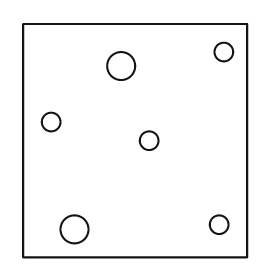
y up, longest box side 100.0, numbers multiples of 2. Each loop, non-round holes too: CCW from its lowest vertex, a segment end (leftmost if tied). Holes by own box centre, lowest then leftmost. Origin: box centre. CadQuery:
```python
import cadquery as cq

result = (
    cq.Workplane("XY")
    .moveTo(-48.0, -50.0)
    .lineTo(48.0, -50.0)
    .lineTo(48.0, 50.0)
    .lineTo(-48.0, 50.0)
    .close()
    .moveTo(-26.0, -38.0)
    .circle(6.0)
    .moveTo(36.0, -36.0)
    .circle(4.0)
    .moveTo(6.0, 0.0)
    .circle(4.0)
    .moveTo(-36.0, 8.0)
    .circle(4.0)
    .moveTo(-6.0, 32.0)
    .circle(6.0)
    .moveTo(38.0, 38.0)
    .circle(4.0)
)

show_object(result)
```